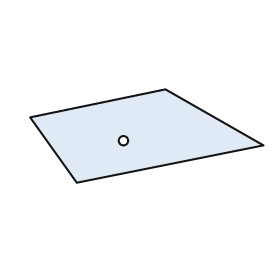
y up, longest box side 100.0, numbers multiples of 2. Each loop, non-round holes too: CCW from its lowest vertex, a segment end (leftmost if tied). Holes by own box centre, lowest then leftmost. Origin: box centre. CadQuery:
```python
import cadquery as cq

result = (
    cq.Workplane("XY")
    .moveTo(-30.0, -20.0)
    .lineTo(50.0, -4.0)
    .lineTo(8.0, 20.0)
    .lineTo(-50.0, 8.0)
    .close()
    .moveTo(-10.0, -2.0)
    .circle(2.0)
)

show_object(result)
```